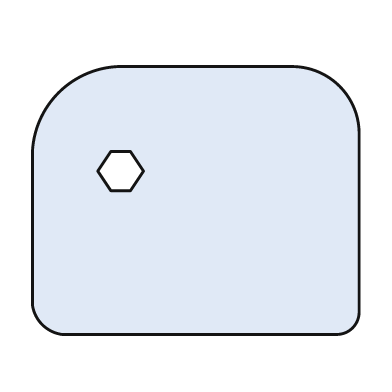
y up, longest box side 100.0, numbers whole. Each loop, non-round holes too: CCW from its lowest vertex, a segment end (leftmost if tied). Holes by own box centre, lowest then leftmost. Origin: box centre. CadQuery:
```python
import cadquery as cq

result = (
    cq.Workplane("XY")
    .moveTo(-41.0, -41.0)
    .lineTo(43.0, -41.0)
    .threePointArc((48.0, -39.0), (50.0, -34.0))
    .lineTo(50.0, 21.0)
    .threePointArc((44.0, 35.0), (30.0, 41.0))
    .lineTo(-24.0, 41.0)
    .threePointArc((-42.0, 33.0), (-50.0, 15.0))
    .lineTo(-50.0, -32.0)
    .threePointArc((-47.0, -38.0), (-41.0, -41.0))
    .close()
    .moveTo(-26.0, 3.0)
    .lineTo(-20.0, 3.0)
    .lineTo(-16.0, 9.0)
    .lineTo(-20.0, 15.0)
    .lineTo(-26.0, 15.0)
    .lineTo(-30.0, 9.0)
    .close()
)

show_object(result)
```